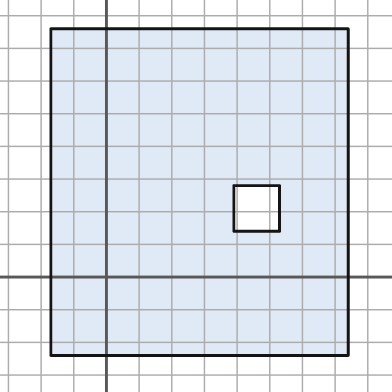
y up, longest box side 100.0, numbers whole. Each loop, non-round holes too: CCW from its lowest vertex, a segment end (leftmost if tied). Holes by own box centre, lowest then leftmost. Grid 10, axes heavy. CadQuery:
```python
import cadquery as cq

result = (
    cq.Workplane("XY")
    .moveTo(-17.0, -24.0)
    .lineTo(74.0, -24.0)
    .lineTo(74.0, 76.0)
    .lineTo(-17.0, 76.0)
    .close()
    .moveTo(39.0, 14.0)
    .lineTo(53.0, 14.0)
    .lineTo(53.0, 28.0)
    .lineTo(39.0, 28.0)
    .close()
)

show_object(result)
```